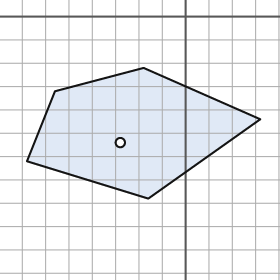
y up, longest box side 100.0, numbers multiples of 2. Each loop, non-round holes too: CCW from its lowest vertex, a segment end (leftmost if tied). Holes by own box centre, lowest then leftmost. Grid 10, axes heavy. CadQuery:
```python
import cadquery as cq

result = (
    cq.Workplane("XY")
    .moveTo(-16.0, -78.0)
    .lineTo(32.0, -44.0)
    .lineTo(-18.0, -22.0)
    .lineTo(-56.0, -32.0)
    .lineTo(-68.0, -62.0)
    .close()
    .moveTo(-28.0, -54.0)
    .circle(2.0)
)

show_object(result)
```